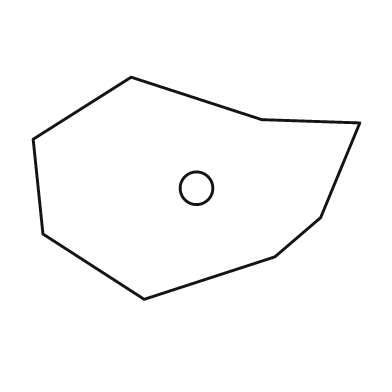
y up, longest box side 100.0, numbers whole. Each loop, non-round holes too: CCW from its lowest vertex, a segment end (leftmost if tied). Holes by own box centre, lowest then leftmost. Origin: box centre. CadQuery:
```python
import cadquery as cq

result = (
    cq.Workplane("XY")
    .moveTo(-16.0, -34.0)
    .lineTo(24.0, -21.0)
    .lineTo(38.0, -9.0)
    .lineTo(50.0, 20.0)
    .lineTo(20.0, 21.0)
    .lineTo(-20.0, 34.0)
    .lineTo(-50.0, 15.0)
    .lineTo(-47.0, -14.0)
    .close()
    .moveTo(0.0, 0.0)
    .circle(5.0)
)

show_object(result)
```